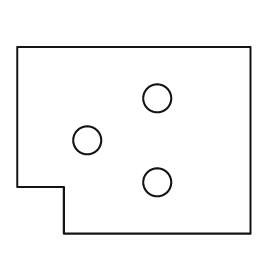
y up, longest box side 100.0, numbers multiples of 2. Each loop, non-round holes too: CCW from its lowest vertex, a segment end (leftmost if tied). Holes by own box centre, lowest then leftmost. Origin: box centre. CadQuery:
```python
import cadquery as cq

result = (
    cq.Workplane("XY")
    .moveTo(-30.0, -40.0)
    .lineTo(50.0, -40.0)
    .lineTo(50.0, 40.0)
    .lineTo(-50.0, 40.0)
    .lineTo(-50.0, -20.0)
    .lineTo(-30.0, -20.0)
    .close()
    .moveTo(10.0, -18.0)
    .circle(6.0)
    .moveTo(-20.0, 0.0)
    .circle(6.0)
    .moveTo(10.0, 18.0)
    .circle(6.0)
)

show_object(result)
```